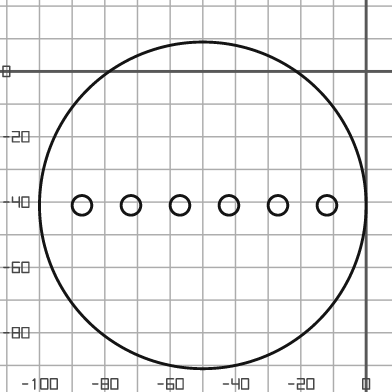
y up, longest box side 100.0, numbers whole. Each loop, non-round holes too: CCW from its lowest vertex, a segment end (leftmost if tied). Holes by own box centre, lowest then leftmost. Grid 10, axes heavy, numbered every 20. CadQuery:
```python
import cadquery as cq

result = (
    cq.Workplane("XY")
    .moveTo(-50.0, -41.0)
    .circle(50.0)
    .moveTo(-87.0, -41.0)
    .circle(3.0)
    .moveTo(-72.0, -41.0)
    .circle(3.0)
    .moveTo(-57.0, -41.0)
    .circle(3.0)
    .moveTo(-42.0, -41.0)
    .circle(3.0)
    .moveTo(-27.0, -41.0)
    .circle(3.0)
    .moveTo(-12.0, -41.0)
    .circle(3.0)
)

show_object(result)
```